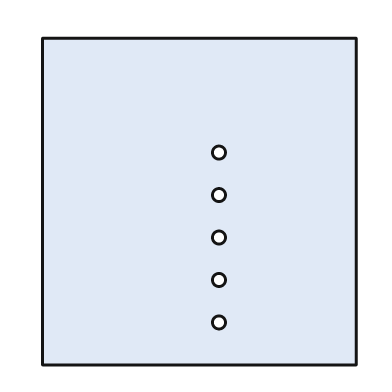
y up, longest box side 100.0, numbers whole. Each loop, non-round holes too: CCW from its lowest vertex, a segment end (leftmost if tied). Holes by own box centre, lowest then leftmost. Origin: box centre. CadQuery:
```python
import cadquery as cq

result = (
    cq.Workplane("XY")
    .moveTo(-48.0, -50.0)
    .lineTo(48.0, -50.0)
    .lineTo(48.0, 50.0)
    .lineTo(-48.0, 50.0)
    .close()
    .moveTo(6.0, -37.0)
    .circle(2.0)
    .moveTo(6.0, -24.0)
    .circle(2.0)
    .moveTo(6.0, -11.0)
    .circle(2.0)
    .moveTo(6.0, 2.0)
    .circle(2.0)
    .moveTo(6.0, 15.0)
    .circle(2.0)
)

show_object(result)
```